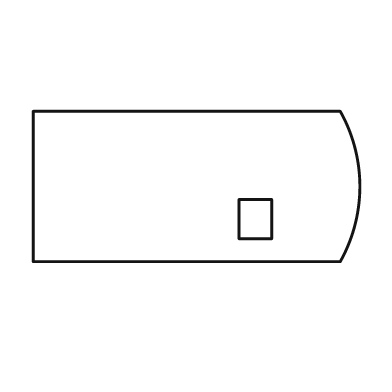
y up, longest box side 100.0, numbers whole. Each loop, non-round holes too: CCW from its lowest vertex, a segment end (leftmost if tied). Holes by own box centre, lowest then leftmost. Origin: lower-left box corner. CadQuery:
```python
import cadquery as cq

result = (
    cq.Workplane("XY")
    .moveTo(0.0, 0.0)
    .lineTo(94.0, 0.0)
    .threePointArc((100.0, 23.0), (94.0, 46.0))
    .lineTo(0.0, 46.0)
    .close()
    .moveTo(63.0, 7.0)
    .lineTo(73.0, 7.0)
    .lineTo(73.0, 19.0)
    .lineTo(63.0, 19.0)
    .close()
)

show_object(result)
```